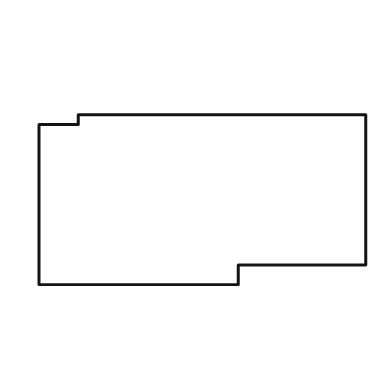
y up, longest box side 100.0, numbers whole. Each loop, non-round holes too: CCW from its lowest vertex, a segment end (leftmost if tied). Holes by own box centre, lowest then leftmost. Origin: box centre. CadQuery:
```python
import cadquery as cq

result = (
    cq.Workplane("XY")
    .moveTo(-50.0, -26.0)
    .lineTo(11.0, -26.0)
    .lineTo(11.0, -20.0)
    .lineTo(50.0, -20.0)
    .lineTo(50.0, 26.0)
    .lineTo(-38.0, 26.0)
    .lineTo(-38.0, 23.0)
    .lineTo(-50.0, 23.0)
    .close()
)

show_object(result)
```